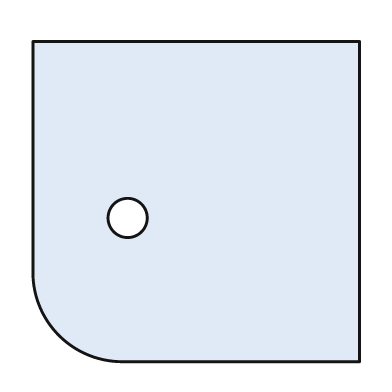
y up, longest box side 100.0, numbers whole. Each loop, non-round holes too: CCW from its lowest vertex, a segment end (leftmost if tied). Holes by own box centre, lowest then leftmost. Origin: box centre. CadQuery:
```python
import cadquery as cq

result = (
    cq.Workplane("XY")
    .moveTo(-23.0, -49.0)
    .lineTo(50.0, -49.0)
    .lineTo(50.0, 49.0)
    .lineTo(-50.0, 49.0)
    .lineTo(-50.0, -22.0)
    .threePointArc((-42.0, -41.0), (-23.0, -49.0))
    .close()
    .moveTo(-21.0, -5.0)
    .circle(6.0)
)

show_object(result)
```